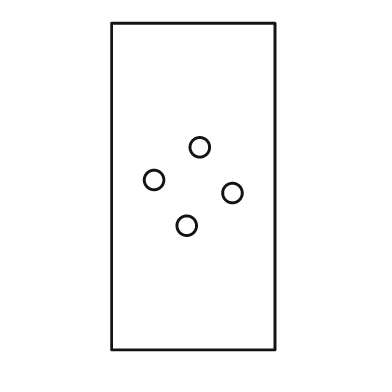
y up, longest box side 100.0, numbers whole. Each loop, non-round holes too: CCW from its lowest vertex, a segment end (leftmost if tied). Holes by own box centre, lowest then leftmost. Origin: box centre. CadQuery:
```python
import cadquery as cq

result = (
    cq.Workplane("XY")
    .moveTo(-25.0, -50.0)
    .lineTo(25.0, -50.0)
    .lineTo(25.0, 50.0)
    .lineTo(-25.0, 50.0)
    .close()
    .moveTo(-2.0, -12.0)
    .circle(3.0)
    .moveTo(12.0, -2.0)
    .circle(3.0)
    .moveTo(-12.0, 2.0)
    .circle(3.0)
    .moveTo(2.0, 12.0)
    .circle(3.0)
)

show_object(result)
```